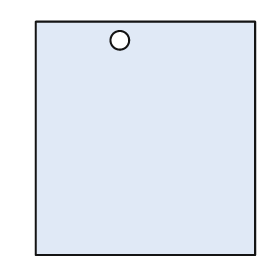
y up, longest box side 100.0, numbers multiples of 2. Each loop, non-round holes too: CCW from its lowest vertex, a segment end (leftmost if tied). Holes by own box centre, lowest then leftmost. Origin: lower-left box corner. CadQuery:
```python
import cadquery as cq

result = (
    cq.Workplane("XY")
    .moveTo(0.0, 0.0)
    .lineTo(94.0, 0.0)
    .lineTo(94.0, 100.0)
    .lineTo(0.0, 100.0)
    .close()
    .moveTo(36.0, 92.0)
    .circle(4.0)
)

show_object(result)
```